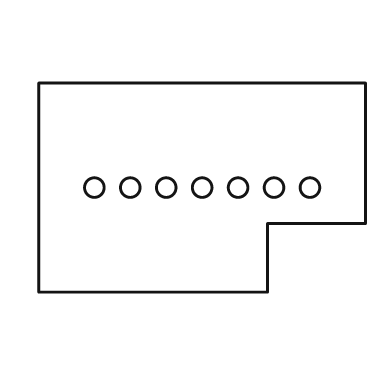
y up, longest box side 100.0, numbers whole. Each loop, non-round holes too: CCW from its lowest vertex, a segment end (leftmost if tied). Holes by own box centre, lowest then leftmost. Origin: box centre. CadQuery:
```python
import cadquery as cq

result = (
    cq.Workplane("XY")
    .moveTo(-50.0, -32.0)
    .lineTo(20.0, -32.0)
    .lineTo(20.0, -11.0)
    .lineTo(50.0, -11.0)
    .lineTo(50.0, 32.0)
    .lineTo(-50.0, 32.0)
    .close()
    .moveTo(-33.0, 0.0)
    .circle(3.0)
    .moveTo(-22.0, 0.0)
    .circle(3.0)
    .moveTo(-11.0, 0.0)
    .circle(3.0)
    .moveTo(0.0, 0.0)
    .circle(3.0)
    .moveTo(11.0, 0.0)
    .circle(3.0)
    .moveTo(22.0, 0.0)
    .circle(3.0)
    .moveTo(33.0, 0.0)
    .circle(3.0)
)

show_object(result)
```